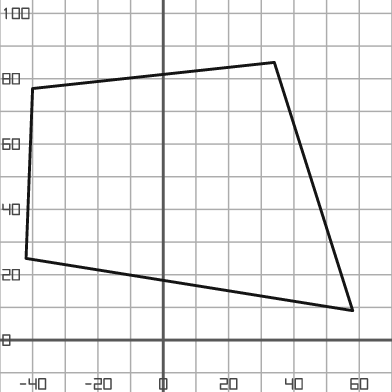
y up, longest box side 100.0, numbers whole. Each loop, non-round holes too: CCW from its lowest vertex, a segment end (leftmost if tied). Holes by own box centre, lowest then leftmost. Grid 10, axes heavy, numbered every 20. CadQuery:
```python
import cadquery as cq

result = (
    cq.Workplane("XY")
    .moveTo(58.0, 9.0)
    .lineTo(34.0, 85.0)
    .lineTo(-40.0, 77.0)
    .lineTo(-42.0, 25.0)
    .close()
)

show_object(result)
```